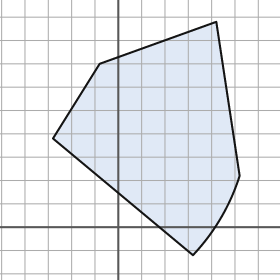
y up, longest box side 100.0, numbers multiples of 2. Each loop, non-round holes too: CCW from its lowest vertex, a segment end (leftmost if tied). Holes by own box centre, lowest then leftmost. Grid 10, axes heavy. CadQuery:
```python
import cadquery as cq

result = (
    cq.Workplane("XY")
    .moveTo(32.0, -12.0)
    .threePointArc((44.0, 4.0), (52.0, 22.0))
    .lineTo(42.0, 88.0)
    .lineTo(-8.0, 70.0)
    .lineTo(-28.0, 38.0)
    .close()
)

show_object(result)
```